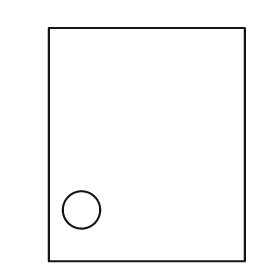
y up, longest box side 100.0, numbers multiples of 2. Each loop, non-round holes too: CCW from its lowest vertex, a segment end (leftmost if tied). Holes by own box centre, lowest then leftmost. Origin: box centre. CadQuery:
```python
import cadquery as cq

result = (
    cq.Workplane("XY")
    .moveTo(-42.0, -50.0)
    .lineTo(42.0, -50.0)
    .lineTo(42.0, 50.0)
    .lineTo(-42.0, 50.0)
    .close()
    .moveTo(-28.0, -28.0)
    .circle(8.0)
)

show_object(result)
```